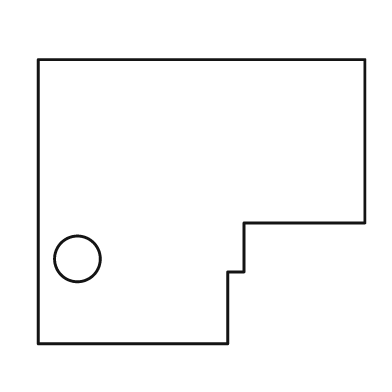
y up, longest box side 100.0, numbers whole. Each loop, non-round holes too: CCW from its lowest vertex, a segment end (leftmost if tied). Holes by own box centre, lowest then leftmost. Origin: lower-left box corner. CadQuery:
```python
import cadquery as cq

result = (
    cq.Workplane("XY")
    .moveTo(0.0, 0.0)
    .lineTo(58.0, 0.0)
    .lineTo(58.0, 22.0)
    .lineTo(63.0, 22.0)
    .lineTo(63.0, 37.0)
    .lineTo(100.0, 37.0)
    .lineTo(100.0, 87.0)
    .lineTo(0.0, 87.0)
    .close()
    .moveTo(12.0, 26.0)
    .circle(7.0)
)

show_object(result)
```